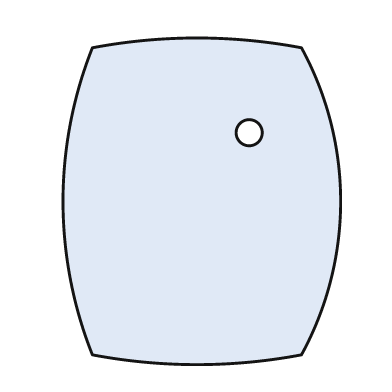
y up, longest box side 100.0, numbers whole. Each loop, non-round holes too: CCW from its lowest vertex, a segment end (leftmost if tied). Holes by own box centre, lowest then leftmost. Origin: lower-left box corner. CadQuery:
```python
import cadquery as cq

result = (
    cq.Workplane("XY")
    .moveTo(9.0, 3.0)
    .threePointArc((41.0, 0.0), (73.0, 3.0))
    .threePointArc((85.0, 50.0), (73.0, 97.0))
    .threePointArc((41.0, 100.0), (9.0, 97.0))
    .threePointArc((0.0, 50.0), (9.0, 3.0))
    .close()
    .moveTo(57.0, 71.0)
    .circle(4.0)
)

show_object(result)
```